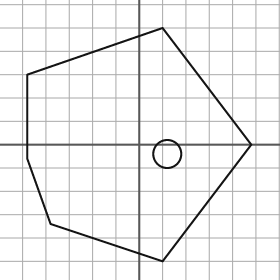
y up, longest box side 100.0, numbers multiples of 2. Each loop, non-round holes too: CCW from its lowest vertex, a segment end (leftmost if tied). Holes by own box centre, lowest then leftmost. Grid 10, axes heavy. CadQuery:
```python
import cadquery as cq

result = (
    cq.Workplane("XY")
    .moveTo(10.0, -50.0)
    .lineTo(48.0, 0.0)
    .lineTo(10.0, 50.0)
    .lineTo(-48.0, 30.0)
    .lineTo(-48.0, -6.0)
    .lineTo(-38.0, -34.0)
    .close()
    .moveTo(12.0, -4.0)
    .circle(6.0)
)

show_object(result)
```